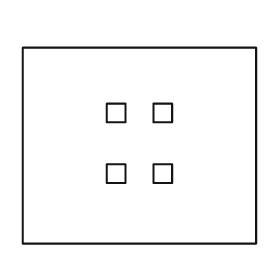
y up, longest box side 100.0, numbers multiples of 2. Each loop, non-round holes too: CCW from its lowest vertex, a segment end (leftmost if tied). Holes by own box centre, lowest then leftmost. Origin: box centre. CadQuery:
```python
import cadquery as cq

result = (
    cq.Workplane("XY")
    .moveTo(-50.0, -42.0)
    .lineTo(50.0, -42.0)
    .lineTo(50.0, 42.0)
    .lineTo(-50.0, 42.0)
    .close()
    .moveTo(-14.0, -16.0)
    .lineTo(-6.0, -16.0)
    .lineTo(-6.0, -8.0)
    .lineTo(-14.0, -8.0)
    .close()
    .moveTo(6.0, -16.0)
    .lineTo(14.0, -16.0)
    .lineTo(14.0, -8.0)
    .lineTo(6.0, -8.0)
    .close()
    .moveTo(-14.0, 10.0)
    .lineTo(-6.0, 10.0)
    .lineTo(-6.0, 18.0)
    .lineTo(-14.0, 18.0)
    .close()
    .moveTo(6.0, 10.0)
    .lineTo(14.0, 10.0)
    .lineTo(14.0, 18.0)
    .lineTo(6.0, 18.0)
    .close()
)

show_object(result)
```